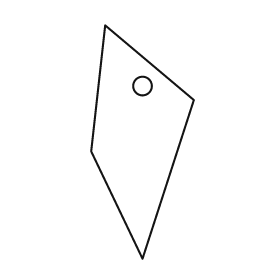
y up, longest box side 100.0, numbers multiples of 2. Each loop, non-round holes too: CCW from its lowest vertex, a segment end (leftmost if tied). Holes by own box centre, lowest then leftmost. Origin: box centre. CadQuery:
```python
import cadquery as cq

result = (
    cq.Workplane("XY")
    .moveTo(0.0, -50.0)
    .lineTo(22.0, 18.0)
    .lineTo(-16.0, 50.0)
    .lineTo(-22.0, -4.0)
    .close()
    .moveTo(0.0, 24.0)
    .circle(4.0)
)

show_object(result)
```